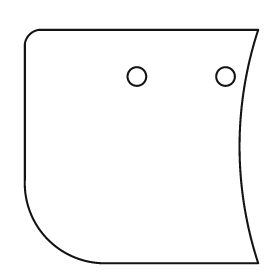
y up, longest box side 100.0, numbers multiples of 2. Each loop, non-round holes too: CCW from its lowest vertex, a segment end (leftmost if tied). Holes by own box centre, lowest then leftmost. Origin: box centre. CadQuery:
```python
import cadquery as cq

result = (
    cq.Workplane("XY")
    .moveTo(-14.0, -50.0)
    .lineTo(50.0, -50.0)
    .threePointArc((42.0, 0.0), (50.0, 50.0))
    .lineTo(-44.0, 50.0)
    .threePointArc((-48.0, 48.0), (-50.0, 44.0))
    .lineTo(-50.0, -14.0)
    .threePointArc((-40.0, -40.0), (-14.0, -50.0))
    .close()
    .moveTo(-2.0, 30.0)
    .circle(4.0)
    .moveTo(36.0, 30.0)
    .circle(4.0)
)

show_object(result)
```